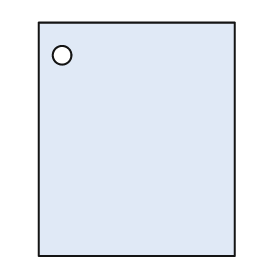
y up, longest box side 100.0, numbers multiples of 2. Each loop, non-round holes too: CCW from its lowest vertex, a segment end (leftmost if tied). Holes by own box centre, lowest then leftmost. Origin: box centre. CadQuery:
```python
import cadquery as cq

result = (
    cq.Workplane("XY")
    .moveTo(-42.0, -50.0)
    .lineTo(42.0, -50.0)
    .lineTo(42.0, 50.0)
    .lineTo(-42.0, 50.0)
    .close()
    .moveTo(-32.0, 36.0)
    .circle(4.0)
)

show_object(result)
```